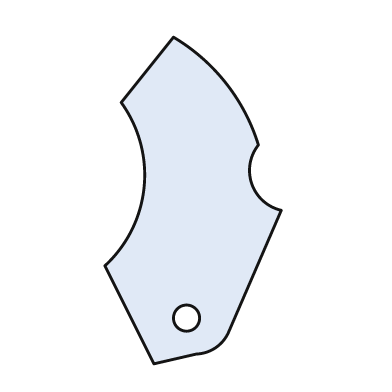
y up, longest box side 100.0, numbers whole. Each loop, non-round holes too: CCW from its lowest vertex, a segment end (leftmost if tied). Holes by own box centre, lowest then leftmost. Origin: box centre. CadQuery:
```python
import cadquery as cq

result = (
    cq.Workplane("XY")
    .moveTo(-12.0, -50.0)
    .lineTo(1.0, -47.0)
    .threePointArc((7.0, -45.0), (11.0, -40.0))
    .lineTo(27.0, -3.0)
    .threePointArc((18.0, 5.0), (20.0, 17.0))
    .threePointArc((10.0, 36.0), (-6.0, 50.0))
    .lineTo(-22.0, 30.0)
    .threePointArc((-15.0, 4.0), (-27.0, -20.0))
    .close()
    .moveTo(-2.0, -36.0)
    .circle(4.0)
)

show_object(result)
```